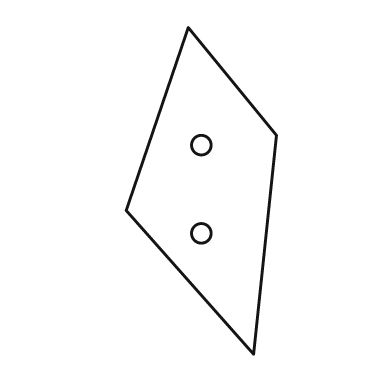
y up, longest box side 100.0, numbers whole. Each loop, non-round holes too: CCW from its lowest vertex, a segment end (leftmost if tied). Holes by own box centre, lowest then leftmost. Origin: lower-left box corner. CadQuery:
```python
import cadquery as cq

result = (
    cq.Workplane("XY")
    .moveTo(39.0, 0.0)
    .lineTo(46.0, 67.0)
    .lineTo(19.0, 100.0)
    .lineTo(0.0, 44.0)
    .close()
    .moveTo(23.0, 37.0)
    .circle(3.0)
    .moveTo(23.0, 64.0)
    .circle(3.0)
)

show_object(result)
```